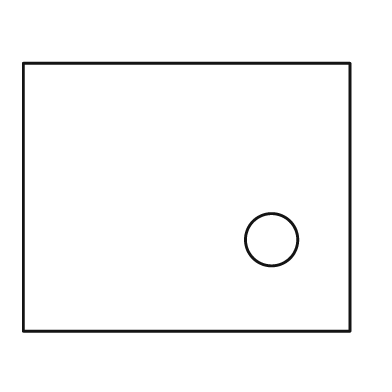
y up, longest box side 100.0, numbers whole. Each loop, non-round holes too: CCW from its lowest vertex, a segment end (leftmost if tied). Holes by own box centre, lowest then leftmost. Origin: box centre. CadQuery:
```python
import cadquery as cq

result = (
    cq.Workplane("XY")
    .moveTo(-50.0, -41.0)
    .lineTo(50.0, -41.0)
    .lineTo(50.0, 41.0)
    .lineTo(-50.0, 41.0)
    .close()
    .moveTo(26.0, -13.0)
    .circle(8.0)
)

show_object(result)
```